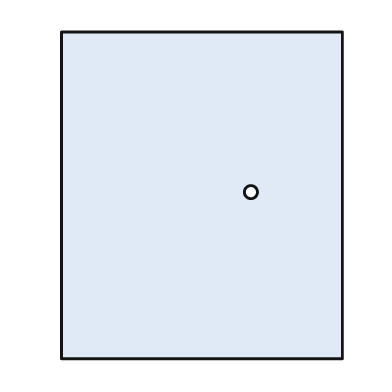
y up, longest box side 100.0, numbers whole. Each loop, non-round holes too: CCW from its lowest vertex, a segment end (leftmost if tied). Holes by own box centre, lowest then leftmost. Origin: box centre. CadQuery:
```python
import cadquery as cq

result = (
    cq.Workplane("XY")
    .moveTo(-43.0, -50.0)
    .lineTo(43.0, -50.0)
    .lineTo(43.0, 50.0)
    .lineTo(-43.0, 50.0)
    .close()
    .moveTo(15.0, 1.0)
    .circle(2.0)
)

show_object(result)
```